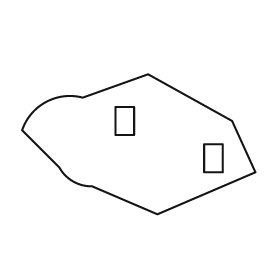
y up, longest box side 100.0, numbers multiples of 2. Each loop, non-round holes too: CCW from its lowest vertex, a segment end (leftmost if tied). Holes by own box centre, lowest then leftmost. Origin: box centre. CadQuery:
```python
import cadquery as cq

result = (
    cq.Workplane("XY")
    .moveTo(8.0, -30.0)
    .lineTo(50.0, -12.0)
    .lineTo(40.0, 10.0)
    .lineTo(4.0, 30.0)
    .lineTo(-24.0, 20.0)
    .threePointArc((-40.0, 18.0), (-50.0, 6.0))
    .lineTo(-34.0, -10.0)
    .threePointArc((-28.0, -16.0), (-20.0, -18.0))
    .close()
    .moveTo(28.0, -12.0)
    .lineTo(36.0, -12.0)
    .lineTo(36.0, 0.0)
    .lineTo(28.0, 0.0)
    .close()
    .moveTo(-10.0, 4.0)
    .lineTo(-2.0, 4.0)
    .lineTo(-2.0, 16.0)
    .lineTo(-10.0, 16.0)
    .close()
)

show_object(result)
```